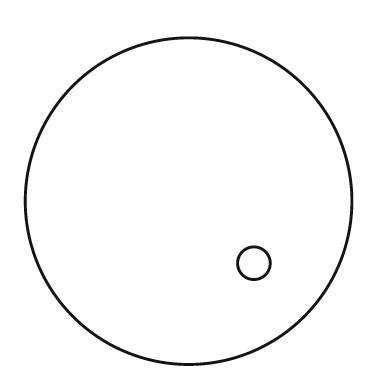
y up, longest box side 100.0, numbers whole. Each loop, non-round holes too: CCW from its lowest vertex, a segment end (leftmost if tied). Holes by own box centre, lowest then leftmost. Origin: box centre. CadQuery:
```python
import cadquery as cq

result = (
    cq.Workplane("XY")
    .moveTo(0.0, 0.0)
    .circle(50.0)
    .moveTo(20.0, -19.0)
    .circle(5.0)
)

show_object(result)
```